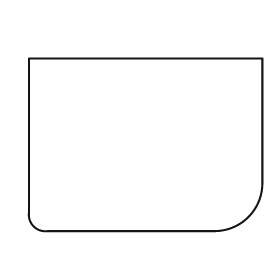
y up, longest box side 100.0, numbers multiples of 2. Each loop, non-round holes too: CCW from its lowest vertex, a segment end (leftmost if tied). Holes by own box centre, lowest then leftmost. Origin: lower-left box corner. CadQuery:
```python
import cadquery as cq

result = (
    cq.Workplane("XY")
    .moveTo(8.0, 0.0)
    .lineTo(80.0, 0.0)
    .threePointArc((94.0, 6.0), (100.0, 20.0))
    .lineTo(100.0, 74.0)
    .lineTo(0.0, 74.0)
    .lineTo(0.0, 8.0)
    .threePointArc((2.0, 2.0), (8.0, 0.0))
    .close()
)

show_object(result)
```